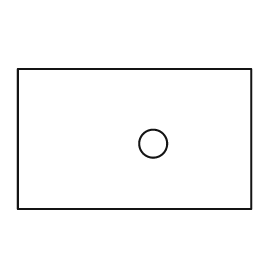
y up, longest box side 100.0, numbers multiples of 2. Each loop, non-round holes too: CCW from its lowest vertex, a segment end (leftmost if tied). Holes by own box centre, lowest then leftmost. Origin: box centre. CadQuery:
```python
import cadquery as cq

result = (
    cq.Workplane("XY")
    .moveTo(-50.0, -30.0)
    .lineTo(50.0, -30.0)
    .lineTo(50.0, 30.0)
    .lineTo(-50.0, 30.0)
    .close()
    .moveTo(8.0, -2.0)
    .circle(6.0)
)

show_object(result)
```